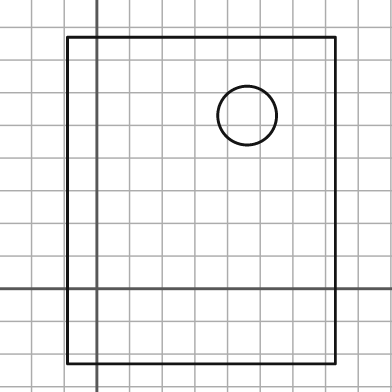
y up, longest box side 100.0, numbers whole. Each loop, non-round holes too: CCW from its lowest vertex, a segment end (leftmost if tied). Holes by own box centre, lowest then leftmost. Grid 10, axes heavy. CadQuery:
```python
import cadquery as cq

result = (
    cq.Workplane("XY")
    .moveTo(-9.0, -23.0)
    .lineTo(73.0, -23.0)
    .lineTo(73.0, 77.0)
    .lineTo(-9.0, 77.0)
    .close()
    .moveTo(46.0, 53.0)
    .circle(9.0)
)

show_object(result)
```